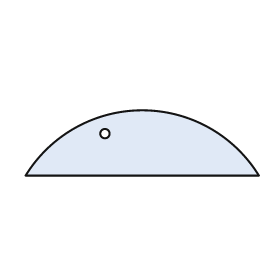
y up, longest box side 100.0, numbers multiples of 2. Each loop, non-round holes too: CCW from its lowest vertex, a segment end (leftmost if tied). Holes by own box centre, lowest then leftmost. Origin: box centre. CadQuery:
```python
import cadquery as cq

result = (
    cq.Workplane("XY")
    .moveTo(-50.0, -14.0)
    .lineTo(50.0, -14.0)
    .threePointArc((0.0, 14.0), (-50.0, -14.0))
    .close()
    .moveTo(-16.0, 4.0)
    .circle(2.0)
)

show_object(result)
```